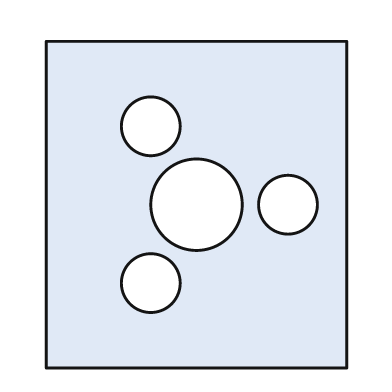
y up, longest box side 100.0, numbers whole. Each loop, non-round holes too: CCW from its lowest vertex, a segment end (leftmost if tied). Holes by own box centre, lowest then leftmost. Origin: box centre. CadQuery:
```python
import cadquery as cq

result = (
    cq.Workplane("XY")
    .moveTo(-46.0, -50.0)
    .lineTo(46.0, -50.0)
    .lineTo(46.0, 50.0)
    .lineTo(-46.0, 50.0)
    .close()
    .moveTo(-14.0, -24.0)
    .circle(9.0)
    .moveTo(0.0, 0.0)
    .circle(14.0)
    .moveTo(28.0, 0.0)
    .circle(9.0)
    .moveTo(-14.0, 24.0)
    .circle(9.0)
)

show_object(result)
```